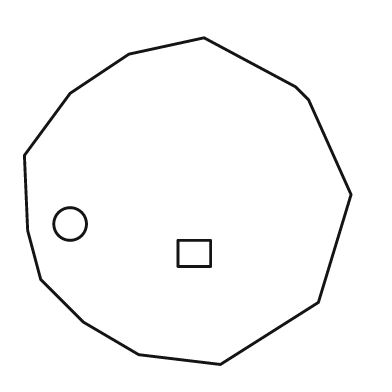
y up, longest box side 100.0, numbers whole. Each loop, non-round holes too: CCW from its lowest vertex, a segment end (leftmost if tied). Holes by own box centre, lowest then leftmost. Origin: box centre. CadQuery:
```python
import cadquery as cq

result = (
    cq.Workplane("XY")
    .moveTo(10.0, -50.0)
    .lineTo(40.0, -31.0)
    .lineTo(50.0, 2.0)
    .lineTo(37.0, 31.0)
    .lineTo(33.0, 35.0)
    .lineTo(5.0, 50.0)
    .lineTo(-18.0, 45.0)
    .lineTo(-36.0, 33.0)
    .lineTo(-50.0, 14.0)
    .lineTo(-49.0, -9.0)
    .lineTo(-45.0, -24.0)
    .lineTo(-32.0, -37.0)
    .lineTo(-15.0, -47.0)
    .close()
    .moveTo(-3.0, -20.0)
    .lineTo(7.0, -20.0)
    .lineTo(7.0, -12.0)
    .lineTo(-3.0, -12.0)
    .close()
    .moveTo(-36.0, -7.0)
    .circle(5.0)
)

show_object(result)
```